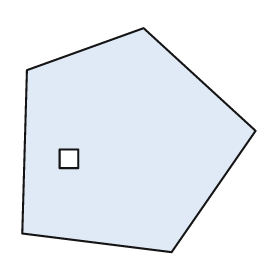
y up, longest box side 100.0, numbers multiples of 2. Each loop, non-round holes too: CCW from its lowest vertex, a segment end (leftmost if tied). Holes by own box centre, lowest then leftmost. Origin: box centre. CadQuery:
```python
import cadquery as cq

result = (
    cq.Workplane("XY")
    .moveTo(14.0, -48.0)
    .lineTo(50.0, 4.0)
    .lineTo(2.0, 48.0)
    .lineTo(-48.0, 30.0)
    .lineTo(-50.0, -40.0)
    .close()
    .moveTo(-34.0, -12.0)
    .lineTo(-26.0, -12.0)
    .lineTo(-26.0, -4.0)
    .lineTo(-34.0, -4.0)
    .close()
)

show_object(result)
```